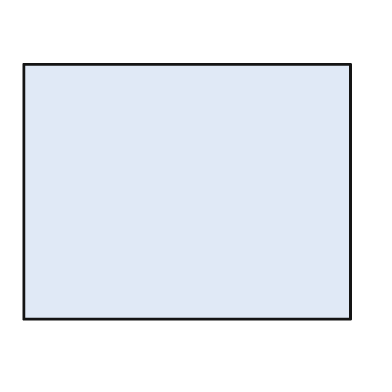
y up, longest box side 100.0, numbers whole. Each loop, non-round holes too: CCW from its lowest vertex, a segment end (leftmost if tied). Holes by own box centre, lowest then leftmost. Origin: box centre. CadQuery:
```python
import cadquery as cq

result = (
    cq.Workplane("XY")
    .moveTo(-50.0, -39.0)
    .lineTo(50.0, -39.0)
    .lineTo(50.0, 39.0)
    .lineTo(-50.0, 39.0)
    .close()
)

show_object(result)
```